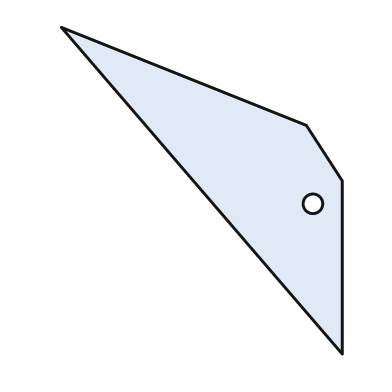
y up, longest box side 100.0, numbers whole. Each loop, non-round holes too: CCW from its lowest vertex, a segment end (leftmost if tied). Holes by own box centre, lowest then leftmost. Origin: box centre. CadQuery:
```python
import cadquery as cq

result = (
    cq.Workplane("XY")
    .moveTo(43.0, -50.0)
    .lineTo(43.0, 3.0)
    .lineTo(32.0, 20.0)
    .lineTo(-43.0, 50.0)
    .close()
    .moveTo(34.0, -4.0)
    .circle(3.0)
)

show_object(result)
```